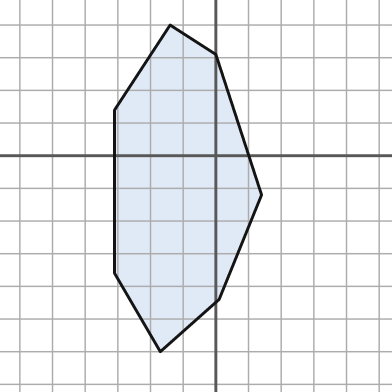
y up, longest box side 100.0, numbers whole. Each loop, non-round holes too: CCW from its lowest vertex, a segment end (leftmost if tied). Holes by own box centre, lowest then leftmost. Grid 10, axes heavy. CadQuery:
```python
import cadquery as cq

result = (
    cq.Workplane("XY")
    .moveTo(-17.0, -60.0)
    .lineTo(1.0, -44.0)
    .lineTo(14.0, -12.0)
    .lineTo(0.0, 31.0)
    .lineTo(-14.0, 40.0)
    .lineTo(-31.0, 14.0)
    .lineTo(-31.0, -36.0)
    .close()
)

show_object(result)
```